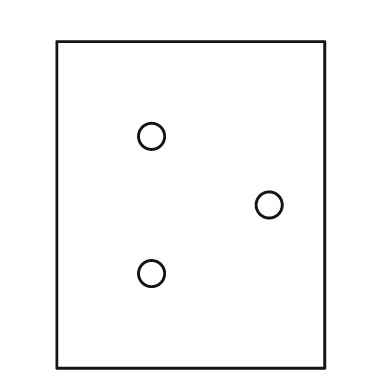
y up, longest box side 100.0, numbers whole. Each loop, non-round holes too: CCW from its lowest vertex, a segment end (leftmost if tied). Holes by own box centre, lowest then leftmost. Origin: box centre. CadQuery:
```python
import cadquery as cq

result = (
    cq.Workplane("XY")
    .moveTo(-41.0, -50.0)
    .lineTo(41.0, -50.0)
    .lineTo(41.0, 50.0)
    .lineTo(-41.0, 50.0)
    .close()
    .moveTo(-12.0, -21.0)
    .circle(4.0)
    .moveTo(24.0, 0.0)
    .circle(4.0)
    .moveTo(-12.0, 21.0)
    .circle(4.0)
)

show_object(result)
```